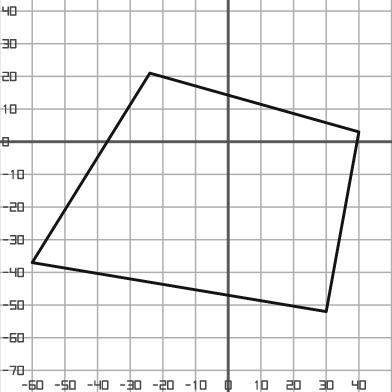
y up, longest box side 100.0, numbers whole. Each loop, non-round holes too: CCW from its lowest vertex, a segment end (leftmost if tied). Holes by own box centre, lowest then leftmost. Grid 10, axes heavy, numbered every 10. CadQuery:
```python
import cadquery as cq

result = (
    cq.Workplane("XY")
    .moveTo(30.0, -52.0)
    .lineTo(40.0, 3.0)
    .lineTo(-24.0, 21.0)
    .lineTo(-60.0, -37.0)
    .close()
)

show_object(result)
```